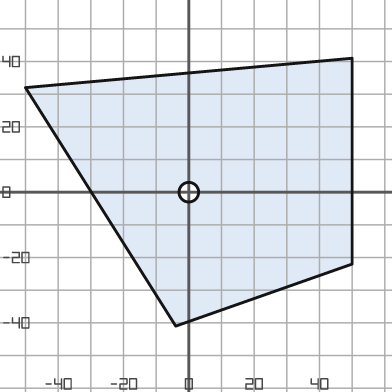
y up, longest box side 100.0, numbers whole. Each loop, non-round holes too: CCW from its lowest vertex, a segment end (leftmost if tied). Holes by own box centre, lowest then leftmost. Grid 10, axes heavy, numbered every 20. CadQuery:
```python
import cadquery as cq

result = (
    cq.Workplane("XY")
    .moveTo(-4.0, -41.0)
    .lineTo(50.0, -22.0)
    .lineTo(50.0, 41.0)
    .lineTo(-50.0, 32.0)
    .close()
    .moveTo(0.0, 0.0)
    .circle(3.0)
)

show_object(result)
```